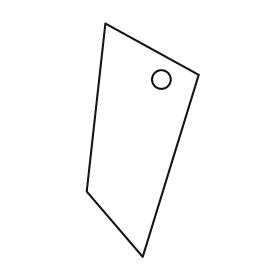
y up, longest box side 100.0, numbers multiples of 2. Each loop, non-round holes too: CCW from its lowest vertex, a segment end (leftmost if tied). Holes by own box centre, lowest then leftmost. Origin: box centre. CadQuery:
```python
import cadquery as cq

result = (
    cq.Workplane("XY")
    .moveTo(0.0, -50.0)
    .lineTo(24.0, 28.0)
    .lineTo(-16.0, 50.0)
    .lineTo(-24.0, -22.0)
    .close()
    .moveTo(8.0, 26.0)
    .circle(4.0)
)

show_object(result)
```